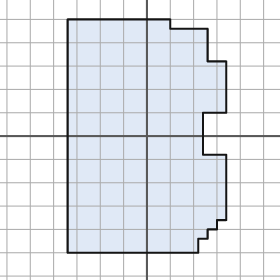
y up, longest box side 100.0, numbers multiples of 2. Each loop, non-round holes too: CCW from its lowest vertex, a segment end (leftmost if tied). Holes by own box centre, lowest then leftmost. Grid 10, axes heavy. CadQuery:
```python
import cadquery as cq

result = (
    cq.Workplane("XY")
    .moveTo(-34.0, -50.0)
    .lineTo(22.0, -50.0)
    .lineTo(22.0, -44.0)
    .lineTo(26.0, -44.0)
    .lineTo(26.0, -40.0)
    .lineTo(30.0, -40.0)
    .lineTo(30.0, -36.0)
    .lineTo(34.0, -36.0)
    .lineTo(34.0, -8.0)
    .lineTo(24.0, -8.0)
    .lineTo(24.0, 10.0)
    .lineTo(34.0, 10.0)
    .lineTo(34.0, 32.0)
    .lineTo(26.0, 32.0)
    .lineTo(26.0, 46.0)
    .lineTo(10.0, 46.0)
    .lineTo(10.0, 50.0)
    .lineTo(-34.0, 50.0)
    .close()
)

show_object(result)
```